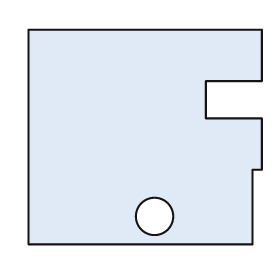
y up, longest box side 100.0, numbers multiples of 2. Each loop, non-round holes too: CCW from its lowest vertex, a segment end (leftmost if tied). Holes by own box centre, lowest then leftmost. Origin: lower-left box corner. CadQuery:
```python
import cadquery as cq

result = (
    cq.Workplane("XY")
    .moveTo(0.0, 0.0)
    .lineTo(96.0, 0.0)
    .lineTo(96.0, 32.0)
    .lineTo(100.0, 32.0)
    .lineTo(100.0, 54.0)
    .lineTo(76.0, 54.0)
    .lineTo(76.0, 70.0)
    .lineTo(100.0, 70.0)
    .lineTo(100.0, 92.0)
    .lineTo(0.0, 92.0)
    .close()
    .moveTo(54.0, 12.0)
    .circle(8.0)
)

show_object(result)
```